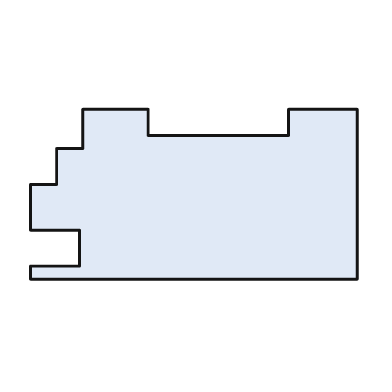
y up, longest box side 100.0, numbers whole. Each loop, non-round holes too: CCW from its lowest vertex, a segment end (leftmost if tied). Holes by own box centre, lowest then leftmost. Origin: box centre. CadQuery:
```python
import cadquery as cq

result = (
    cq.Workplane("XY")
    .moveTo(-50.0, -26.0)
    .lineTo(50.0, -26.0)
    .lineTo(50.0, 26.0)
    .lineTo(29.0, 26.0)
    .lineTo(29.0, 18.0)
    .lineTo(-14.0, 18.0)
    .lineTo(-14.0, 26.0)
    .lineTo(-34.0, 26.0)
    .lineTo(-34.0, 14.0)
    .lineTo(-42.0, 14.0)
    .lineTo(-42.0, 3.0)
    .lineTo(-50.0, 3.0)
    .lineTo(-50.0, -11.0)
    .lineTo(-35.0, -11.0)
    .lineTo(-35.0, -22.0)
    .lineTo(-50.0, -22.0)
    .close()
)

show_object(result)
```